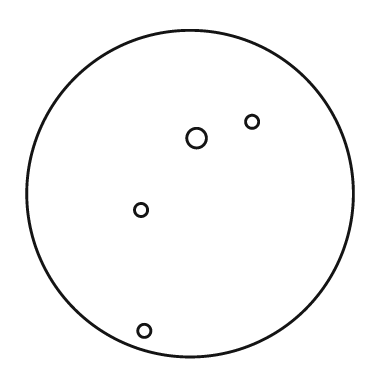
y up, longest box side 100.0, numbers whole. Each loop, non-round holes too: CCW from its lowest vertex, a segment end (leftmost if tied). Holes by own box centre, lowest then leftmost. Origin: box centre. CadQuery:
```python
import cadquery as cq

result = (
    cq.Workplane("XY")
    .moveTo(0.0, 0.0)
    .circle(50.0)
    .moveTo(-14.0, -42.0)
    .circle(2.0)
    .moveTo(-15.0, -5.0)
    .circle(2.0)
    .moveTo(2.0, 17.0)
    .circle(3.0)
    .moveTo(19.0, 22.0)
    .circle(2.0)
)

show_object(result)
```